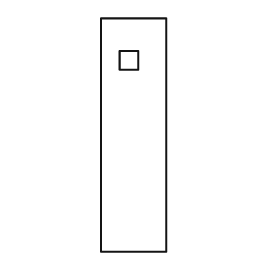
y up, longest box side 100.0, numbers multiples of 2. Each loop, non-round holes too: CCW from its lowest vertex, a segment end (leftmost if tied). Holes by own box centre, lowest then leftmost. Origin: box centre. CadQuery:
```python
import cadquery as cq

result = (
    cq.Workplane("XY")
    .moveTo(-14.0, -50.0)
    .lineTo(14.0, -50.0)
    .lineTo(14.0, 50.0)
    .lineTo(-14.0, 50.0)
    .close()
    .moveTo(-6.0, 28.0)
    .lineTo(2.0, 28.0)
    .lineTo(2.0, 36.0)
    .lineTo(-6.0, 36.0)
    .close()
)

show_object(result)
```